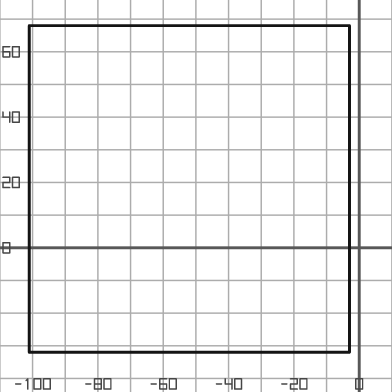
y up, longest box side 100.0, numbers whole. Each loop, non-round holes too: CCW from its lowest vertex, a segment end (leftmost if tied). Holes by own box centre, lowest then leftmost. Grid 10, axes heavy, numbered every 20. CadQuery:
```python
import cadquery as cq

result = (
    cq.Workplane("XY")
    .moveTo(-101.0, -32.0)
    .lineTo(-3.0, -32.0)
    .lineTo(-3.0, 68.0)
    .lineTo(-101.0, 68.0)
    .close()
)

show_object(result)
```